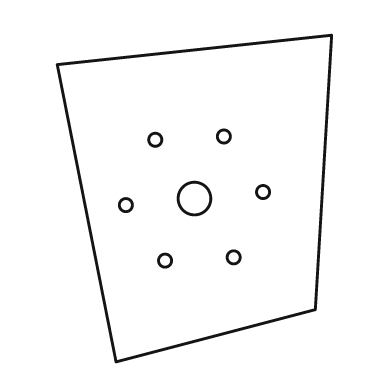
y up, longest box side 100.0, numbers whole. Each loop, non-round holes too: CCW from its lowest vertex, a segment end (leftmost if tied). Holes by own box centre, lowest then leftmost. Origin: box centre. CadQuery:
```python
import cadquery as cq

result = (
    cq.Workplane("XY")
    .moveTo(-24.0, -50.0)
    .lineTo(37.0, -34.0)
    .lineTo(42.0, 50.0)
    .lineTo(-42.0, 41.0)
    .close()
    .moveTo(-9.0, -19.0)
    .circle(2.0)
    .moveTo(12.0, -18.0)
    .circle(2.0)
    .moveTo(-21.0, -2.0)
    .circle(2.0)
    .moveTo(0.0, 0.0)
    .circle(5.0)
    .moveTo(21.0, 2.0)
    .circle(2.0)
    .moveTo(-12.0, 18.0)
    .circle(2.0)
    .moveTo(9.0, 19.0)
    .circle(2.0)
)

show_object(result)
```